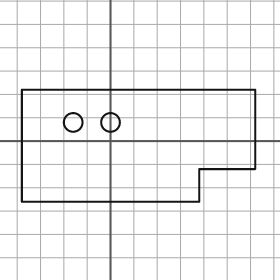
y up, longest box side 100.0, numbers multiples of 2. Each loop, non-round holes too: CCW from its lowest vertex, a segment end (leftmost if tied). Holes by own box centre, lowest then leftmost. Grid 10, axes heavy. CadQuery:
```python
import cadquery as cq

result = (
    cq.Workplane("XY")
    .moveTo(-38.0, -26.0)
    .lineTo(38.0, -26.0)
    .lineTo(38.0, -12.0)
    .lineTo(62.0, -12.0)
    .lineTo(62.0, 22.0)
    .lineTo(-38.0, 22.0)
    .close()
    .moveTo(-16.0, 8.0)
    .circle(4.0)
    .moveTo(0.0, 8.0)
    .circle(4.0)
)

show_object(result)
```